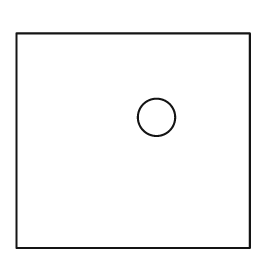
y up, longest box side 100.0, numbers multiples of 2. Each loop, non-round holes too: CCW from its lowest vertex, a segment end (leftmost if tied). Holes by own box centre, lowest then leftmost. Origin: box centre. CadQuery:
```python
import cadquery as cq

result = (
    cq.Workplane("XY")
    .moveTo(-50.0, -46.0)
    .lineTo(50.0, -46.0)
    .lineTo(50.0, 46.0)
    .lineTo(-50.0, 46.0)
    .close()
    .moveTo(10.0, 10.0)
    .circle(8.0)
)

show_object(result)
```